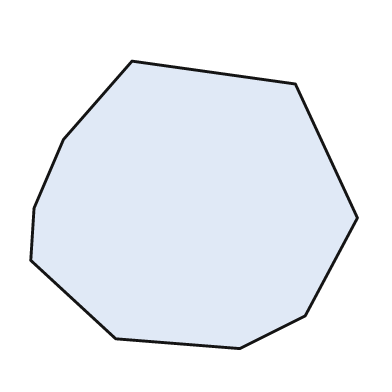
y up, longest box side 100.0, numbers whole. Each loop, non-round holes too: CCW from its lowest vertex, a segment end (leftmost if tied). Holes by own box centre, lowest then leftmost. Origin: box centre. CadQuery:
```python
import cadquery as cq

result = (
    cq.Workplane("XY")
    .moveTo(14.0, -44.0)
    .lineTo(34.0, -34.0)
    .lineTo(50.0, -4.0)
    .lineTo(31.0, 37.0)
    .lineTo(-19.0, 44.0)
    .lineTo(-40.0, 20.0)
    .lineTo(-49.0, -1.0)
    .lineTo(-50.0, -17.0)
    .lineTo(-24.0, -41.0)
    .close()
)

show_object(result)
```